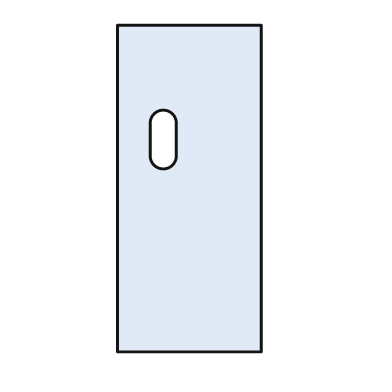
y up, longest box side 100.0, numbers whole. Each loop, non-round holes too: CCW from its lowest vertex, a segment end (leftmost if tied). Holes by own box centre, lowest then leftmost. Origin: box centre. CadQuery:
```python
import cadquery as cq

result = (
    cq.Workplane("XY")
    .moveTo(-22.0, -50.0)
    .lineTo(22.0, -50.0)
    .lineTo(22.0, 50.0)
    .lineTo(-22.0, 50.0)
    .close()
    .moveTo(-12.0, 10.0)
    .threePointArc((-8.0, 6.0), (-4.0, 10.0))
    .lineTo(-4.0, 20.0)
    .threePointArc((-8.0, 24.0), (-12.0, 20.0))
    .close()
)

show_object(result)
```